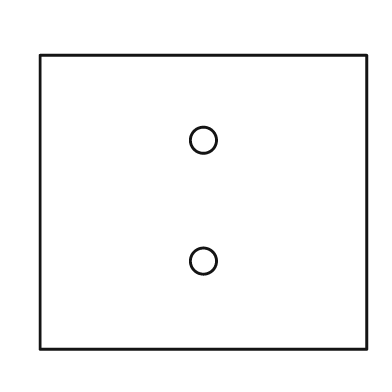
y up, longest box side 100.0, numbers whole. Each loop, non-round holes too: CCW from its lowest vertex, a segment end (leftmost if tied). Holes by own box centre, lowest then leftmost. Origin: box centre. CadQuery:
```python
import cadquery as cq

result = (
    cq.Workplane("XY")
    .moveTo(-50.0, -45.0)
    .lineTo(50.0, -45.0)
    .lineTo(50.0, 45.0)
    .lineTo(-50.0, 45.0)
    .close()
    .moveTo(0.0, -18.0)
    .circle(4.0)
    .moveTo(0.0, 19.0)
    .circle(4.0)
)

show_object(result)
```